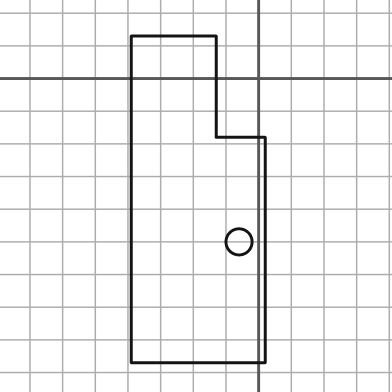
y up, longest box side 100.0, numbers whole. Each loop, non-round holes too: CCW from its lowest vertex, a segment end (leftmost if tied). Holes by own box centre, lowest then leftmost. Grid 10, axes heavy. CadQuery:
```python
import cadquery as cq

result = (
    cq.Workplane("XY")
    .moveTo(-39.0, -87.0)
    .lineTo(2.0, -87.0)
    .lineTo(2.0, -18.0)
    .lineTo(-13.0, -18.0)
    .lineTo(-13.0, 13.0)
    .lineTo(-39.0, 13.0)
    .close()
    .moveTo(-6.0, -50.0)
    .circle(4.0)
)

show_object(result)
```